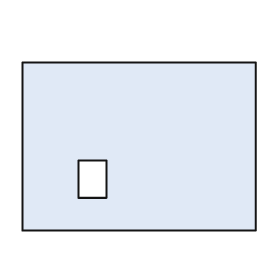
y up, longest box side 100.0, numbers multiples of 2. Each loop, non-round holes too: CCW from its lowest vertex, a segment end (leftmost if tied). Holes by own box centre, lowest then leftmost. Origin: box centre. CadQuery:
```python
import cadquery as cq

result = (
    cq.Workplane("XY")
    .moveTo(-50.0, -36.0)
    .lineTo(50.0, -36.0)
    .lineTo(50.0, 36.0)
    .lineTo(-50.0, 36.0)
    .close()
    .moveTo(-26.0, -22.0)
    .lineTo(-14.0, -22.0)
    .lineTo(-14.0, -6.0)
    .lineTo(-26.0, -6.0)
    .close()
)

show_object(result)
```